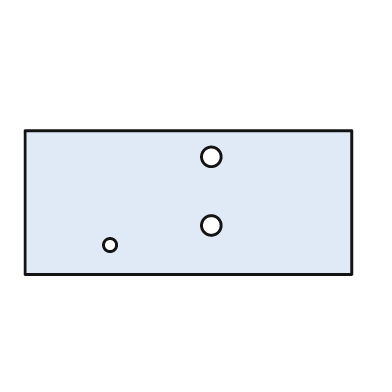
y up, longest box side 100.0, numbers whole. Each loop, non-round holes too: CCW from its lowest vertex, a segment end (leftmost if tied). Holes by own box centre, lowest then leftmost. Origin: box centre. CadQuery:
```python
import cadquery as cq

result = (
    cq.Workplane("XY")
    .moveTo(-50.0, -22.0)
    .lineTo(50.0, -22.0)
    .lineTo(50.0, 22.0)
    .lineTo(-50.0, 22.0)
    .close()
    .moveTo(-24.0, -13.0)
    .circle(2.0)
    .moveTo(7.0, -7.0)
    .circle(3.0)
    .moveTo(7.0, 14.0)
    .circle(3.0)
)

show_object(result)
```